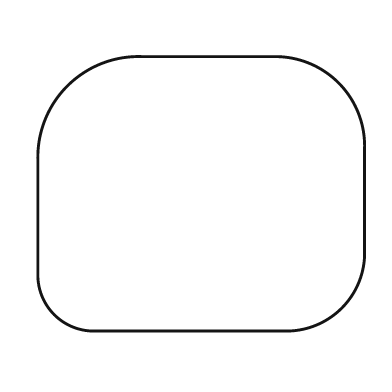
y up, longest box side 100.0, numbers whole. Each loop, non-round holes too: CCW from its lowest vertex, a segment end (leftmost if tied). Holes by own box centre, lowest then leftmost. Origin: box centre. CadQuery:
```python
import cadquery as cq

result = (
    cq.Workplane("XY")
    .moveTo(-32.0, -42.0)
    .lineTo(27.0, -42.0)
    .threePointArc((43.0, -35.0), (50.0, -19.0))
    .lineTo(50.0, 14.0)
    .threePointArc((42.0, 34.0), (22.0, 42.0))
    .lineTo(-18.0, 42.0)
    .threePointArc((-41.0, 33.0), (-50.0, 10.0))
    .lineTo(-50.0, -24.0)
    .threePointArc((-45.0, -37.0), (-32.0, -42.0))
    .close()
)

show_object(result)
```